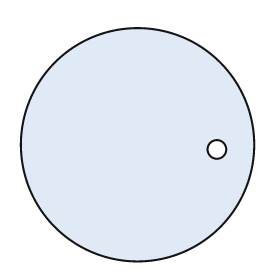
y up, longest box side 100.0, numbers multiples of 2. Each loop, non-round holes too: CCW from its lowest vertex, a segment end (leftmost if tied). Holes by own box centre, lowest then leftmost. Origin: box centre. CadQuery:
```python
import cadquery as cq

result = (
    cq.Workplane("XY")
    .moveTo(0.0, 0.0)
    .circle(50.0)
    .moveTo(34.0, -2.0)
    .circle(4.0)
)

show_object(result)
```